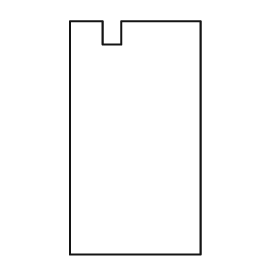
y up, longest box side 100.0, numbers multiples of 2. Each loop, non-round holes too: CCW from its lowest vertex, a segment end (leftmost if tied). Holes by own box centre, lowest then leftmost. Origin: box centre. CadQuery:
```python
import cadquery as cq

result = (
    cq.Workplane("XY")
    .moveTo(-28.0, -50.0)
    .lineTo(28.0, -50.0)
    .lineTo(28.0, 50.0)
    .lineTo(-6.0, 50.0)
    .lineTo(-6.0, 40.0)
    .lineTo(-14.0, 40.0)
    .lineTo(-14.0, 50.0)
    .lineTo(-28.0, 50.0)
    .close()
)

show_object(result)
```